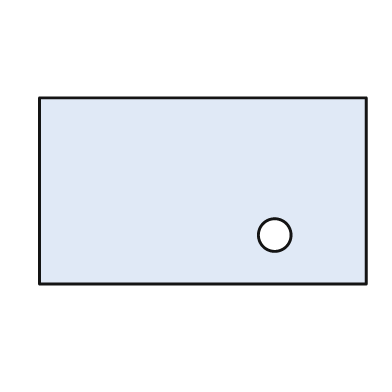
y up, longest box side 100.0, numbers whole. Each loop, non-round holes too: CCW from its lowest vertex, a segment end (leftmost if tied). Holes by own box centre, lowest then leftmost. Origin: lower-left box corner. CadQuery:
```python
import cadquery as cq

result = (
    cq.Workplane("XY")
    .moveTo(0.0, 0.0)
    .lineTo(100.0, 0.0)
    .lineTo(100.0, 57.0)
    .lineTo(0.0, 57.0)
    .close()
    .moveTo(72.0, 15.0)
    .circle(5.0)
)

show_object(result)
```